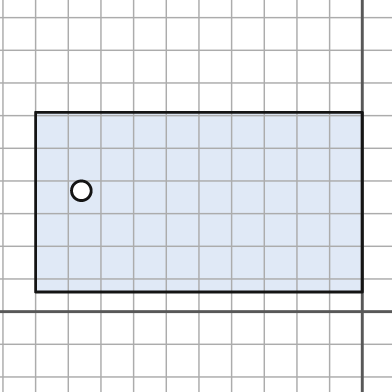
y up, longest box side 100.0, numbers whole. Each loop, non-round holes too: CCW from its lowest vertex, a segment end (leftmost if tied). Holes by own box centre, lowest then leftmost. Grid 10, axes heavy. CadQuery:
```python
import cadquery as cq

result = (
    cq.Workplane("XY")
    .moveTo(-100.0, 6.0)
    .lineTo(0.0, 6.0)
    .lineTo(0.0, 61.0)
    .lineTo(-100.0, 61.0)
    .close()
    .moveTo(-86.0, 37.0)
    .circle(3.0)
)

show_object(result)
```